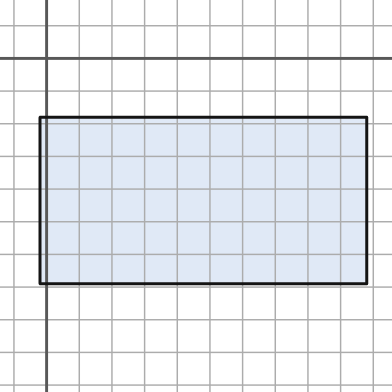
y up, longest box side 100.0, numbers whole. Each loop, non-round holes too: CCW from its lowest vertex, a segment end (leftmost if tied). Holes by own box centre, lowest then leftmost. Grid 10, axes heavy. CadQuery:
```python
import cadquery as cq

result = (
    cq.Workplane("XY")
    .moveTo(-2.0, -69.0)
    .lineTo(98.0, -69.0)
    .lineTo(98.0, -18.0)
    .lineTo(-2.0, -18.0)
    .close()
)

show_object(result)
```